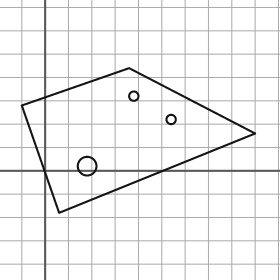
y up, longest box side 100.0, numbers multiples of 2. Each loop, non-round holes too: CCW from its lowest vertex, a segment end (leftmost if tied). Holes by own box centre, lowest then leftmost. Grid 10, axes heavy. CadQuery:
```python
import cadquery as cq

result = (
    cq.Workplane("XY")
    .moveTo(6.0, -18.0)
    .lineTo(90.0, 16.0)
    .lineTo(36.0, 44.0)
    .lineTo(-10.0, 28.0)
    .close()
    .moveTo(18.0, 2.0)
    .circle(4.0)
    .moveTo(54.0, 22.0)
    .circle(2.0)
    .moveTo(38.0, 32.0)
    .circle(2.0)
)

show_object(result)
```